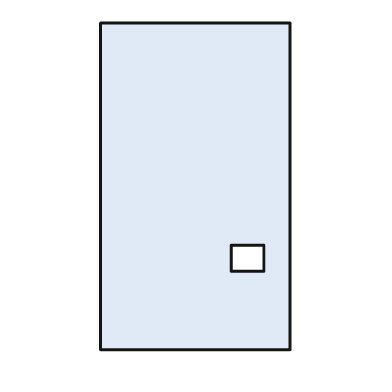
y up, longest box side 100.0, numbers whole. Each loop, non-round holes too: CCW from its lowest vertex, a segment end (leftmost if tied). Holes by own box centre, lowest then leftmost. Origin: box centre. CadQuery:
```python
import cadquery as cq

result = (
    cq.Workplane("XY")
    .moveTo(-29.0, -50.0)
    .lineTo(29.0, -50.0)
    .lineTo(29.0, 50.0)
    .lineTo(-29.0, 50.0)
    .close()
    .moveTo(11.0, -26.0)
    .lineTo(21.0, -26.0)
    .lineTo(21.0, -18.0)
    .lineTo(11.0, -18.0)
    .close()
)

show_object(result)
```